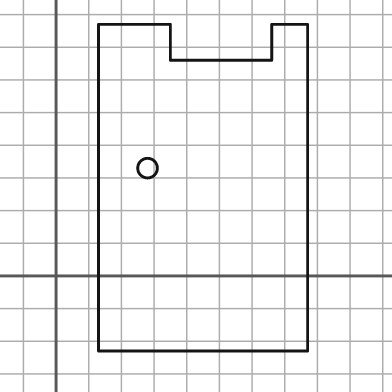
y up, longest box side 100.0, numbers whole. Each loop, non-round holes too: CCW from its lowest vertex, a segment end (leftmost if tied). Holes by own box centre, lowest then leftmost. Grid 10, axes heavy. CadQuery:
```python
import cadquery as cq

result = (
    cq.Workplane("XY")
    .moveTo(13.0, -23.0)
    .lineTo(77.0, -23.0)
    .lineTo(77.0, 77.0)
    .lineTo(66.0, 77.0)
    .lineTo(66.0, 66.0)
    .lineTo(35.0, 66.0)
    .lineTo(35.0, 77.0)
    .lineTo(13.0, 77.0)
    .close()
    .moveTo(28.0, 33.0)
    .circle(3.0)
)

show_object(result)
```